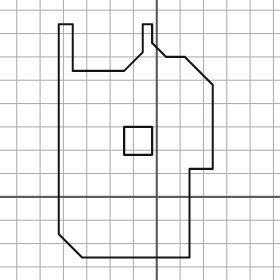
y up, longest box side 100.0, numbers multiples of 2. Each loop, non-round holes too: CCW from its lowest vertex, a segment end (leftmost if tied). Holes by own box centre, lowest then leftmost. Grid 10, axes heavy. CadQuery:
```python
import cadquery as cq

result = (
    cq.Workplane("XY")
    .moveTo(-32.0, -26.0)
    .lineTo(14.0, -26.0)
    .lineTo(14.0, 12.0)
    .lineTo(24.0, 12.0)
    .lineTo(24.0, 48.0)
    .lineTo(12.0, 60.0)
    .lineTo(4.0, 60.0)
    .lineTo(-2.0, 66.0)
    .lineTo(-2.0, 74.0)
    .lineTo(-6.0, 74.0)
    .lineTo(-6.0, 62.0)
    .lineTo(-14.0, 54.0)
    .lineTo(-36.0, 54.0)
    .lineTo(-36.0, 74.0)
    .lineTo(-42.0, 74.0)
    .lineTo(-42.0, -16.0)
    .close()
    .moveTo(-14.0, 18.0)
    .lineTo(-2.0, 18.0)
    .lineTo(-2.0, 30.0)
    .lineTo(-14.0, 30.0)
    .close()
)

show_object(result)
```